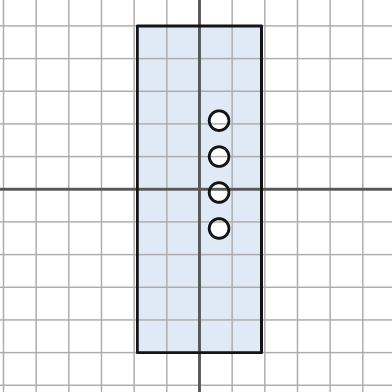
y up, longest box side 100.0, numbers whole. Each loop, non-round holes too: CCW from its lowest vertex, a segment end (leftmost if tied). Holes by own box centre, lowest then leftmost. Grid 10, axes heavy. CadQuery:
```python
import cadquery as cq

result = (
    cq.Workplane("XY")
    .moveTo(-19.0, -50.0)
    .lineTo(19.0, -50.0)
    .lineTo(19.0, 50.0)
    .lineTo(-19.0, 50.0)
    .close()
    .moveTo(6.0, -12.0)
    .circle(3.0)
    .moveTo(6.0, -1.0)
    .circle(3.0)
    .moveTo(6.0, 10.0)
    .circle(3.0)
    .moveTo(6.0, 21.0)
    .circle(3.0)
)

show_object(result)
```